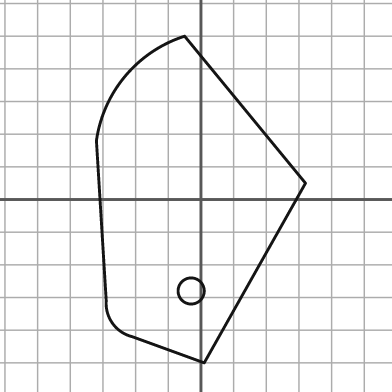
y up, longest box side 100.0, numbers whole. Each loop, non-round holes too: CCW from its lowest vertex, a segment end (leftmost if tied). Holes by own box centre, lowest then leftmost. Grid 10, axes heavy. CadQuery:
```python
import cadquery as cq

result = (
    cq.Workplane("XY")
    .moveTo(1.0, -50.0)
    .lineTo(32.0, 5.0)
    .lineTo(-5.0, 50.0)
    .threePointArc((-23.0, 38.0), (-32.0, 18.0))
    .lineTo(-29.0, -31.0)
    .threePointArc((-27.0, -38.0), (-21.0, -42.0))
    .close()
    .moveTo(-3.0, -28.0)
    .circle(4.0)
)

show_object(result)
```